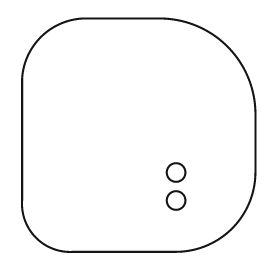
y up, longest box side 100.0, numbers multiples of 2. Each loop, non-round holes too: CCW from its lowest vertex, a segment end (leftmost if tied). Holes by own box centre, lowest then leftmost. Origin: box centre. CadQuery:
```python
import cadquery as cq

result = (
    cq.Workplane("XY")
    .moveTo(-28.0, -50.0)
    .lineTo(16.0, -50.0)
    .threePointArc((40.0, -40.0), (50.0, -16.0))
    .lineTo(50.0, 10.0)
    .threePointArc((38.0, 38.0), (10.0, 50.0))
    .lineTo(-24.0, 50.0)
    .threePointArc((-42.0, 42.0), (-50.0, 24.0))
    .lineTo(-50.0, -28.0)
    .threePointArc((-44.0, -44.0), (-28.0, -50.0))
    .close()
    .moveTo(16.0, -28.0)
    .circle(4.0)
    .moveTo(16.0, -16.0)
    .circle(4.0)
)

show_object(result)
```